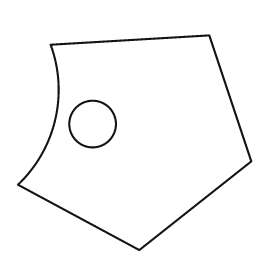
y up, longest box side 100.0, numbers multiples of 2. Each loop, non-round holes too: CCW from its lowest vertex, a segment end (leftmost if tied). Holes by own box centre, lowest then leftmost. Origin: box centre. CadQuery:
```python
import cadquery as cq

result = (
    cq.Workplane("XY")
    .moveTo(2.0, -46.0)
    .lineTo(50.0, -8.0)
    .lineTo(32.0, 46.0)
    .lineTo(-36.0, 42.0)
    .threePointArc((-34.0, 10.0), (-50.0, -18.0))
    .close()
    .moveTo(-18.0, 8.0)
    .circle(10.0)
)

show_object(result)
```